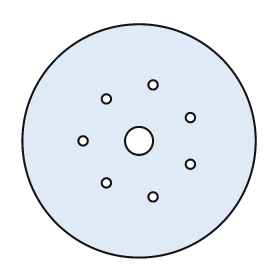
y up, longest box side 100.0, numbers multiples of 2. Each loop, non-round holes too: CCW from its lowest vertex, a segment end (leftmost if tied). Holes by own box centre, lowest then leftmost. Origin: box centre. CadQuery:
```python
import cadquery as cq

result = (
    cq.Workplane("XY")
    .moveTo(0.0, 0.0)
    .circle(50.0)
    .moveTo(6.0, -24.0)
    .circle(2.0)
    .moveTo(-14.0, -18.0)
    .circle(2.0)
    .moveTo(22.0, -10.0)
    .circle(2.0)
    .moveTo(-24.0, 0.0)
    .circle(2.0)
    .moveTo(0.0, 0.0)
    .circle(6.0)
    .moveTo(22.0, 10.0)
    .circle(2.0)
    .moveTo(-14.0, 18.0)
    .circle(2.0)
    .moveTo(6.0, 24.0)
    .circle(2.0)
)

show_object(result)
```